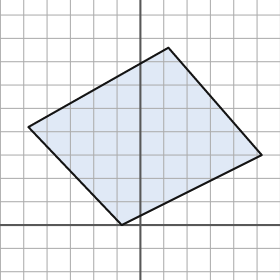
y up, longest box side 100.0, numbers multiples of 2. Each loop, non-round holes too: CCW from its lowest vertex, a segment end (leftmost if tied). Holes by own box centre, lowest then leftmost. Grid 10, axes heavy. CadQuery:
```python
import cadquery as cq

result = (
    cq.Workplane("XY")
    .moveTo(-8.0, 0.0)
    .lineTo(52.0, 30.0)
    .lineTo(12.0, 76.0)
    .lineTo(-48.0, 42.0)
    .close()
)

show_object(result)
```